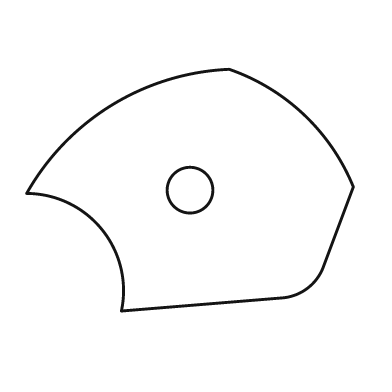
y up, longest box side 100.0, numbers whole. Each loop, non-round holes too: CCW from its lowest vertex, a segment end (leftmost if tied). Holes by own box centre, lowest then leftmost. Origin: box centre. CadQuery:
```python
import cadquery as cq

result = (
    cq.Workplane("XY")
    .moveTo(-21.0, -37.0)
    .lineTo(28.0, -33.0)
    .threePointArc((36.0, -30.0), (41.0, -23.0))
    .lineTo(50.0, 1.0)
    .threePointArc((35.0, 23.0), (12.0, 37.0))
    .threePointArc((-24.0, 26.0), (-50.0, -1.0))
    .threePointArc((-27.0, -12.0), (-21.0, -37.0))
    .close()
    .moveTo(0.0, 0.0)
    .circle(7.0)
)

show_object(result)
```